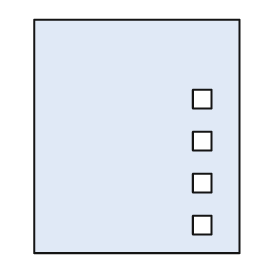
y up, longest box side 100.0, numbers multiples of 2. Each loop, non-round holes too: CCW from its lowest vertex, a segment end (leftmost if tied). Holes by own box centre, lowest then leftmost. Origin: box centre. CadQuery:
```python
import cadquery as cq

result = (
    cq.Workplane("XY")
    .moveTo(-44.0, -50.0)
    .lineTo(44.0, -50.0)
    .lineTo(44.0, 50.0)
    .lineTo(-44.0, 50.0)
    .close()
    .moveTo(24.0, -42.0)
    .lineTo(32.0, -42.0)
    .lineTo(32.0, -34.0)
    .lineTo(24.0, -34.0)
    .close()
    .moveTo(24.0, -24.0)
    .lineTo(32.0, -24.0)
    .lineTo(32.0, -16.0)
    .lineTo(24.0, -16.0)
    .close()
    .moveTo(24.0, -6.0)
    .lineTo(32.0, -6.0)
    .lineTo(32.0, 2.0)
    .lineTo(24.0, 2.0)
    .close()
    .moveTo(24.0, 12.0)
    .lineTo(32.0, 12.0)
    .lineTo(32.0, 20.0)
    .lineTo(24.0, 20.0)
    .close()
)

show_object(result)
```